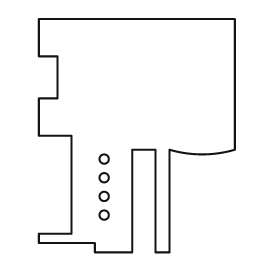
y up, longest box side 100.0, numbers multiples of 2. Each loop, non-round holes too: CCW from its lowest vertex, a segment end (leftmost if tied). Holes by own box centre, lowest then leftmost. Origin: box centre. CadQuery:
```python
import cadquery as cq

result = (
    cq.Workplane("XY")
    .moveTo(-18.0, -50.0)
    .lineTo(-2.0, -50.0)
    .lineTo(-2.0, -6.0)
    .lineTo(8.0, -6.0)
    .lineTo(8.0, -50.0)
    .lineTo(14.0, -50.0)
    .lineTo(14.0, -6.0)
    .threePointArc((28.0, -8.0), (42.0, -6.0))
    .lineTo(42.0, 50.0)
    .lineTo(-42.0, 50.0)
    .lineTo(-42.0, 34.0)
    .lineTo(-34.0, 34.0)
    .lineTo(-34.0, 16.0)
    .lineTo(-42.0, 16.0)
    .lineTo(-42.0, 0.0)
    .lineTo(-28.0, 0.0)
    .lineTo(-28.0, -42.0)
    .lineTo(-42.0, -42.0)
    .lineTo(-42.0, -46.0)
    .lineTo(-18.0, -46.0)
    .close()
    .moveTo(-14.0, -34.0)
    .circle(2.0)
    .moveTo(-14.0, -26.0)
    .circle(2.0)
    .moveTo(-14.0, -18.0)
    .circle(2.0)
    .moveTo(-14.0, -10.0)
    .circle(2.0)
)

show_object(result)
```